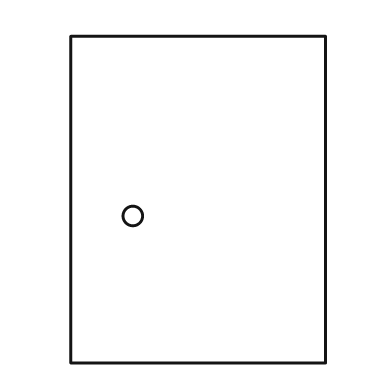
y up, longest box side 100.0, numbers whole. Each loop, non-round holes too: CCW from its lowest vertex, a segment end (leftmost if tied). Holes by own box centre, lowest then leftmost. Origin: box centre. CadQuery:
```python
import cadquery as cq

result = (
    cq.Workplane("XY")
    .moveTo(-39.0, -50.0)
    .lineTo(39.0, -50.0)
    .lineTo(39.0, 50.0)
    .lineTo(-39.0, 50.0)
    .close()
    .moveTo(-20.0, -5.0)
    .circle(3.0)
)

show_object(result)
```